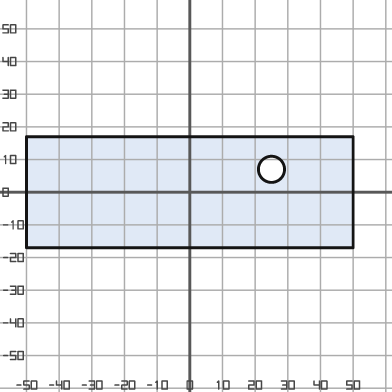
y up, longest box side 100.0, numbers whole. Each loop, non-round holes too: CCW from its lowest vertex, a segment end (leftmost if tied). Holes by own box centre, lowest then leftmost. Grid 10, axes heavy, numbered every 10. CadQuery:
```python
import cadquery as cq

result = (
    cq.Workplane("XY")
    .moveTo(-50.0, -17.0)
    .lineTo(50.0, -17.0)
    .lineTo(50.0, 17.0)
    .lineTo(-50.0, 17.0)
    .close()
    .moveTo(25.0, 7.0)
    .circle(4.0)
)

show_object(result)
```